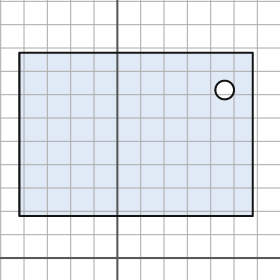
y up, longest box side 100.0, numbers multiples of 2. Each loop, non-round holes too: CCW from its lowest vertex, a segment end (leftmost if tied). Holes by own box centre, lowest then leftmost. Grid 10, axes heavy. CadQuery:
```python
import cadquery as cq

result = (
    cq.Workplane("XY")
    .moveTo(-42.0, 18.0)
    .lineTo(58.0, 18.0)
    .lineTo(58.0, 88.0)
    .lineTo(-42.0, 88.0)
    .close()
    .moveTo(46.0, 72.0)
    .circle(4.0)
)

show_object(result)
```